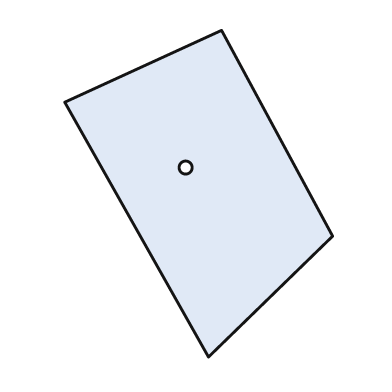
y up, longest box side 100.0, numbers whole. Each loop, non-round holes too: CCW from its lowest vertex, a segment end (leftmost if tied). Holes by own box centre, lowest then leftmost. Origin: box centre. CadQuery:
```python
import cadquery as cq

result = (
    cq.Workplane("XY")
    .moveTo(3.0, -50.0)
    .lineTo(41.0, -13.0)
    .lineTo(7.0, 50.0)
    .lineTo(-41.0, 28.0)
    .close()
    .moveTo(-4.0, 8.0)
    .circle(2.0)
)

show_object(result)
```